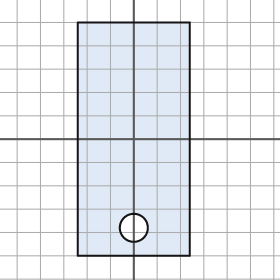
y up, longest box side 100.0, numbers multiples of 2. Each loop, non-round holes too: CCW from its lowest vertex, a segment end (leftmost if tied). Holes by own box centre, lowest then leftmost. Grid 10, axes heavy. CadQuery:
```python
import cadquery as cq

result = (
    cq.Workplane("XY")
    .moveTo(-24.0, -50.0)
    .lineTo(24.0, -50.0)
    .lineTo(24.0, 50.0)
    .lineTo(-24.0, 50.0)
    .close()
    .moveTo(0.0, -38.0)
    .circle(6.0)
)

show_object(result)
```